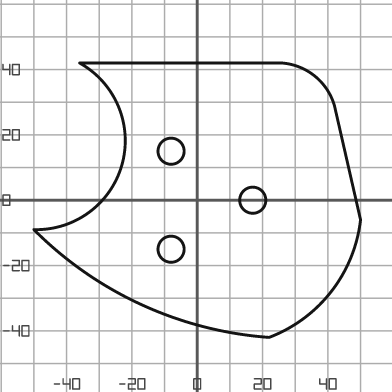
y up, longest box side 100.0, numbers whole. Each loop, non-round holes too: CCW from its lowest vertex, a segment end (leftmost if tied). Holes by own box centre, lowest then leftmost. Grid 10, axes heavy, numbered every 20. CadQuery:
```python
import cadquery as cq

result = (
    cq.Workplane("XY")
    .moveTo(22.0, -42.0)
    .threePointArc((41.0, -28.0), (50.0, -6.0))
    .lineTo(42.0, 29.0)
    .threePointArc((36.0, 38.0), (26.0, 42.0))
    .lineTo(-36.0, 42.0)
    .threePointArc((-23.0, 11.0), (-50.0, -9.0))
    .threePointArc((-17.0, -32.0), (22.0, -42.0))
    .close()
    .moveTo(-8.0, -15.0)
    .circle(4.0)
    .moveTo(17.0, 0.0)
    .circle(4.0)
    .moveTo(-8.0, 15.0)
    .circle(4.0)
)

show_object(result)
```